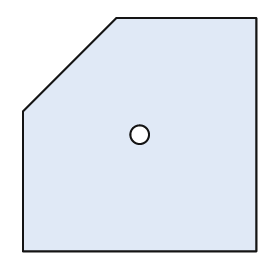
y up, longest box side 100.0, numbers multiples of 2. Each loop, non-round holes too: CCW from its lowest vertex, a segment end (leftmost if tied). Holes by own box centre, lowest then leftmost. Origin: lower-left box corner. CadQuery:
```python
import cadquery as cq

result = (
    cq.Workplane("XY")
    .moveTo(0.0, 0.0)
    .lineTo(100.0, 0.0)
    .lineTo(100.0, 100.0)
    .lineTo(40.0, 100.0)
    .lineTo(0.0, 60.0)
    .close()
    .moveTo(50.0, 50.0)
    .circle(4.0)
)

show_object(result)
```